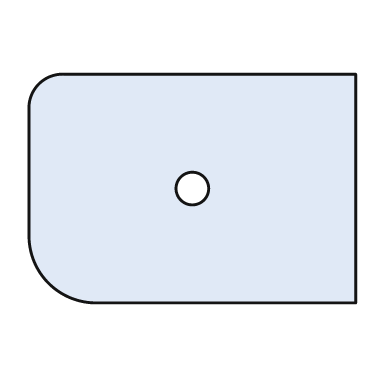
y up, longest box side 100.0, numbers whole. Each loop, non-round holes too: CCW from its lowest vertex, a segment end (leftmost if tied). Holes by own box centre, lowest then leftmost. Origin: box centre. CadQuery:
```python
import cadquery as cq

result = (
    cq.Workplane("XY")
    .moveTo(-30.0, -35.0)
    .lineTo(50.0, -35.0)
    .lineTo(50.0, 35.0)
    .lineTo(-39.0, 35.0)
    .threePointArc((-47.0, 32.0), (-50.0, 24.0))
    .lineTo(-50.0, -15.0)
    .threePointArc((-44.0, -29.0), (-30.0, -35.0))
    .close()
    .moveTo(0.0, 0.0)
    .circle(5.0)
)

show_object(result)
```